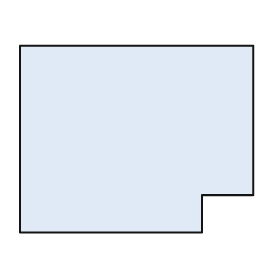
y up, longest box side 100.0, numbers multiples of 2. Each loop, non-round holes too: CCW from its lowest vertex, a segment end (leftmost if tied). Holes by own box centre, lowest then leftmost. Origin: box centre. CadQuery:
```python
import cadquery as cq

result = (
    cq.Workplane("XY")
    .moveTo(-50.0, -40.0)
    .lineTo(28.0, -40.0)
    .lineTo(28.0, -24.0)
    .lineTo(50.0, -24.0)
    .lineTo(50.0, 40.0)
    .lineTo(-50.0, 40.0)
    .close()
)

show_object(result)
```